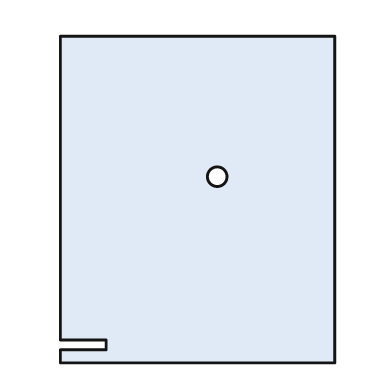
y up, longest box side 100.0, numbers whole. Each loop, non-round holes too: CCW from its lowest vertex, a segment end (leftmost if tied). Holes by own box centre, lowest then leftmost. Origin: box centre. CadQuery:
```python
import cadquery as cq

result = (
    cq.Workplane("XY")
    .moveTo(-42.0, -50.0)
    .lineTo(42.0, -50.0)
    .lineTo(42.0, 50.0)
    .lineTo(-42.0, 50.0)
    .lineTo(-42.0, -43.0)
    .lineTo(-28.0, -43.0)
    .lineTo(-28.0, -46.0)
    .lineTo(-42.0, -46.0)
    .close()
    .moveTo(6.0, 7.0)
    .circle(3.0)
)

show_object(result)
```